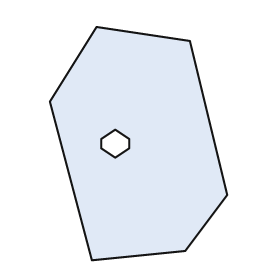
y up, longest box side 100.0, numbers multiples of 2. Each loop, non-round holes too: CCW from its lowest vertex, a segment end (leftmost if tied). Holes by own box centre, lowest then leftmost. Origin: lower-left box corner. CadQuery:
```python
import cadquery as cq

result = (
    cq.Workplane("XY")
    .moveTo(18.0, 0.0)
    .lineTo(58.0, 4.0)
    .lineTo(76.0, 28.0)
    .lineTo(60.0, 94.0)
    .lineTo(20.0, 100.0)
    .lineTo(0.0, 68.0)
    .close()
    .moveTo(28.0, 44.0)
    .lineTo(34.0, 48.0)
    .lineTo(34.0, 52.0)
    .lineTo(28.0, 56.0)
    .lineTo(22.0, 52.0)
    .lineTo(22.0, 48.0)
    .close()
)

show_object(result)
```